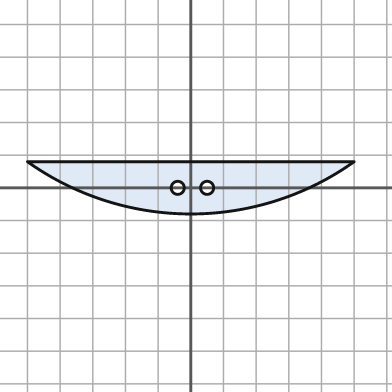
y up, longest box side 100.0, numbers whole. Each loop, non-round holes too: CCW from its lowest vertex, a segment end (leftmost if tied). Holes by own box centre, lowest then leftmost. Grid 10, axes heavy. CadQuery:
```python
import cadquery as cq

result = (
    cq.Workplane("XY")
    .moveTo(-50.0, 8.0)
    .threePointArc((0.0, -8.0), (50.0, 8.0))
    .close()
    .moveTo(-4.0, 0.0)
    .circle(2.0)
    .moveTo(5.0, 0.0)
    .circle(2.0)
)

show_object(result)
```